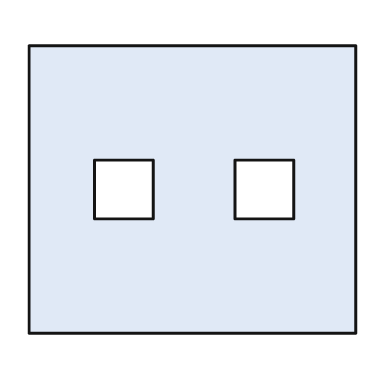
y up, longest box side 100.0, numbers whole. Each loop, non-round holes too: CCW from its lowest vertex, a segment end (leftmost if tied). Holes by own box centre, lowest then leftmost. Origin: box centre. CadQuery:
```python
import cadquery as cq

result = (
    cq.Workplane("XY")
    .moveTo(-50.0, -44.0)
    .lineTo(50.0, -44.0)
    .lineTo(50.0, 44.0)
    .lineTo(-50.0, 44.0)
    .close()
    .moveTo(-30.0, -9.0)
    .lineTo(-12.0, -9.0)
    .lineTo(-12.0, 9.0)
    .lineTo(-30.0, 9.0)
    .close()
    .moveTo(13.0, -9.0)
    .lineTo(31.0, -9.0)
    .lineTo(31.0, 9.0)
    .lineTo(13.0, 9.0)
    .close()
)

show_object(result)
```